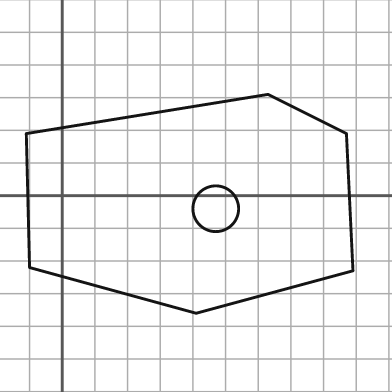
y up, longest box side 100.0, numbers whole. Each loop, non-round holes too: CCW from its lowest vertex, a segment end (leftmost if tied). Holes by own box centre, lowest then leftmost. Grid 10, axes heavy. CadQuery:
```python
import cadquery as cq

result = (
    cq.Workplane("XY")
    .moveTo(41.0, -36.0)
    .lineTo(89.0, -23.0)
    .lineTo(87.0, 19.0)
    .lineTo(63.0, 31.0)
    .lineTo(-11.0, 19.0)
    .lineTo(-10.0, -22.0)
    .close()
    .moveTo(47.0, -4.0)
    .circle(7.0)
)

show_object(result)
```